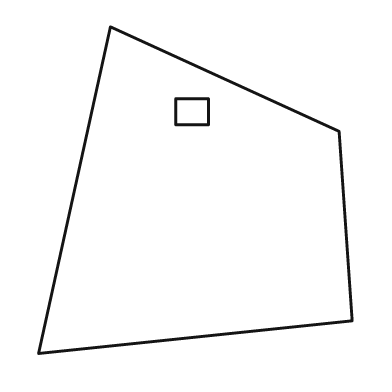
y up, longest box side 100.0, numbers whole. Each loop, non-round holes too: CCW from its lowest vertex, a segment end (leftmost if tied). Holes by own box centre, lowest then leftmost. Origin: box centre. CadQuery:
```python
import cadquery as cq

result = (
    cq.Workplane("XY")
    .moveTo(-48.0, -50.0)
    .lineTo(48.0, -40.0)
    .lineTo(44.0, 18.0)
    .lineTo(-26.0, 50.0)
    .close()
    .moveTo(-6.0, 20.0)
    .lineTo(4.0, 20.0)
    .lineTo(4.0, 28.0)
    .lineTo(-6.0, 28.0)
    .close()
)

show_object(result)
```